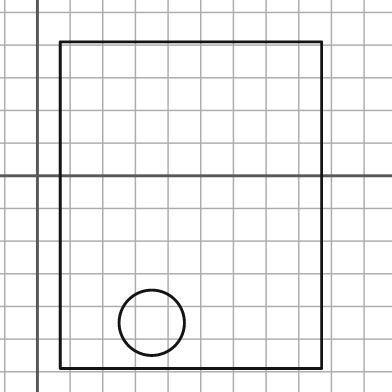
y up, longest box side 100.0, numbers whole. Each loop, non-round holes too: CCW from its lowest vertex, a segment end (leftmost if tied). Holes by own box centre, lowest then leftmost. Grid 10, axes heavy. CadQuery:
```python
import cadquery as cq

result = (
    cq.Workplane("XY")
    .moveTo(7.0, -59.0)
    .lineTo(87.0, -59.0)
    .lineTo(87.0, 41.0)
    .lineTo(7.0, 41.0)
    .close()
    .moveTo(35.0, -45.0)
    .circle(10.0)
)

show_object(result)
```